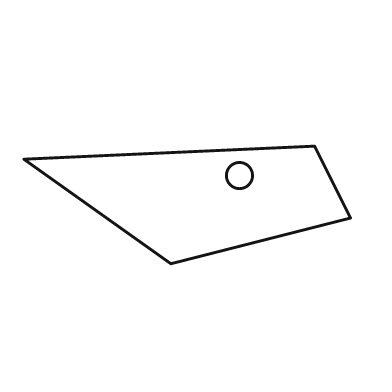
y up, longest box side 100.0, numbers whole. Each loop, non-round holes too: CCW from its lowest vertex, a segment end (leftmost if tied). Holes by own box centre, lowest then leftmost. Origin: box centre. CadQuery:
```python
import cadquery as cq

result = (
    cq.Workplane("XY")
    .moveTo(-5.0, -18.0)
    .lineTo(50.0, -4.0)
    .lineTo(39.0, 18.0)
    .lineTo(-50.0, 14.0)
    .close()
    .moveTo(16.0, 9.0)
    .circle(4.0)
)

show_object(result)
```